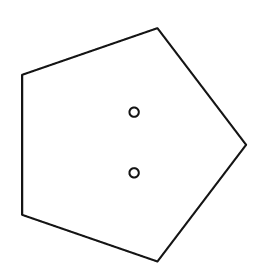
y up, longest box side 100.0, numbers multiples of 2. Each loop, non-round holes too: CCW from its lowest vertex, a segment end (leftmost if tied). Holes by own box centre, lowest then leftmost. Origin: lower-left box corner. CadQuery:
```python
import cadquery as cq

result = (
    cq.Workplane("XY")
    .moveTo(58.0, 0.0)
    .lineTo(96.0, 50.0)
    .lineTo(58.0, 100.0)
    .lineTo(0.0, 80.0)
    .lineTo(0.0, 20.0)
    .close()
    .moveTo(48.0, 38.0)
    .circle(2.0)
    .moveTo(48.0, 64.0)
    .circle(2.0)
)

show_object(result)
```